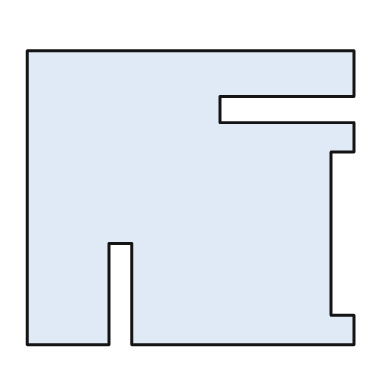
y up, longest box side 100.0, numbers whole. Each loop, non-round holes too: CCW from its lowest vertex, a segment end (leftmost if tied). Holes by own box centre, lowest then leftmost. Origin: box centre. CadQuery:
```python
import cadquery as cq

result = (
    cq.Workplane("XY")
    .moveTo(-50.0, -45.0)
    .lineTo(-25.0, -45.0)
    .lineTo(-25.0, -14.0)
    .lineTo(-18.0, -14.0)
    .lineTo(-18.0, -45.0)
    .lineTo(50.0, -45.0)
    .lineTo(50.0, -36.0)
    .lineTo(43.0, -36.0)
    .lineTo(43.0, 14.0)
    .lineTo(50.0, 14.0)
    .lineTo(50.0, 23.0)
    .lineTo(9.0, 23.0)
    .lineTo(9.0, 31.0)
    .lineTo(50.0, 31.0)
    .lineTo(50.0, 45.0)
    .lineTo(-50.0, 45.0)
    .close()
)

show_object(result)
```